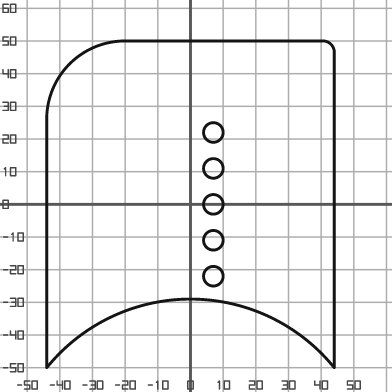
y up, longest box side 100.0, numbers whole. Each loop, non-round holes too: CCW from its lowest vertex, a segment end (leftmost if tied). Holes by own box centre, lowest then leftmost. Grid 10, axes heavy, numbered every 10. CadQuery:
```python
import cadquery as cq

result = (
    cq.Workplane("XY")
    .moveTo(-44.0, -50.0)
    .threePointArc((0.0, -29.0), (44.0, -50.0))
    .lineTo(44.0, 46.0)
    .threePointArc((43.0, 49.0), (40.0, 50.0))
    .lineTo(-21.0, 50.0)
    .threePointArc((-37.0, 43.0), (-44.0, 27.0))
    .close()
    .moveTo(7.0, -22.0)
    .circle(3.0)
    .moveTo(7.0, -11.0)
    .circle(3.0)
    .moveTo(7.0, 0.0)
    .circle(3.0)
    .moveTo(7.0, 11.0)
    .circle(3.0)
    .moveTo(7.0, 22.0)
    .circle(3.0)
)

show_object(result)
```